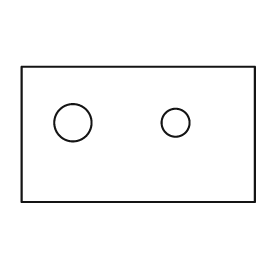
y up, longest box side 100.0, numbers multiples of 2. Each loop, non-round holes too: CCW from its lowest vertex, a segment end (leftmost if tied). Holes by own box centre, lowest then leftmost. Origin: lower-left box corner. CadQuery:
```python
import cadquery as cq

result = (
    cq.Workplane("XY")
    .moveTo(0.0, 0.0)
    .lineTo(100.0, 0.0)
    .lineTo(100.0, 58.0)
    .lineTo(0.0, 58.0)
    .close()
    .moveTo(22.0, 34.0)
    .circle(8.0)
    .moveTo(66.0, 34.0)
    .circle(6.0)
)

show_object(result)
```